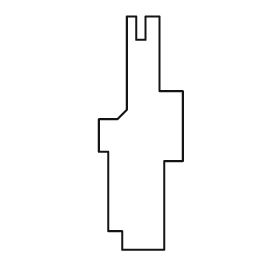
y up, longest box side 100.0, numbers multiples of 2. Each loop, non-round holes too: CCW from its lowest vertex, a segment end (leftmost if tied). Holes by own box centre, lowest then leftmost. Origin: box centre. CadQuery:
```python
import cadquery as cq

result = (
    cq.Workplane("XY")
    .moveTo(-8.0, -50.0)
    .lineTo(10.0, -50.0)
    .lineTo(10.0, -12.0)
    .lineTo(18.0, -12.0)
    .lineTo(18.0, 18.0)
    .lineTo(8.0, 18.0)
    .lineTo(8.0, 50.0)
    .lineTo(2.0, 50.0)
    .lineTo(2.0, 40.0)
    .lineTo(-2.0, 40.0)
    .lineTo(-2.0, 50.0)
    .lineTo(-6.0, 50.0)
    .lineTo(-6.0, 10.0)
    .lineTo(-10.0, 6.0)
    .lineTo(-18.0, 6.0)
    .lineTo(-18.0, -8.0)
    .lineTo(-14.0, -8.0)
    .lineTo(-14.0, -42.0)
    .lineTo(-8.0, -42.0)
    .close()
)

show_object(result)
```